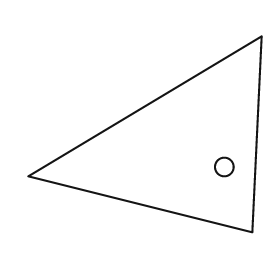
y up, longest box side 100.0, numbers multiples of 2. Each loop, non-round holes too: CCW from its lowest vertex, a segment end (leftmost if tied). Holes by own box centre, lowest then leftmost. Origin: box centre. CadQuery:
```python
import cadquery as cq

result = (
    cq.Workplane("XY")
    .moveTo(46.0, -42.0)
    .lineTo(50.0, 42.0)
    .lineTo(-50.0, -18.0)
    .close()
    .moveTo(34.0, -14.0)
    .circle(4.0)
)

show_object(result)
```